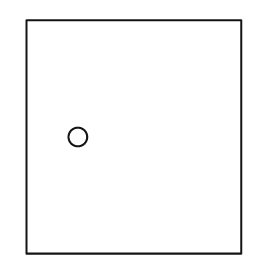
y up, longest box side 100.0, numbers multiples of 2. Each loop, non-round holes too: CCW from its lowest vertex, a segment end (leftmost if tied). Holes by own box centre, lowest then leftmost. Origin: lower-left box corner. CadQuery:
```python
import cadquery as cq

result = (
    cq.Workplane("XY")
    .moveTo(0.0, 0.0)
    .lineTo(92.0, 0.0)
    .lineTo(92.0, 100.0)
    .lineTo(0.0, 100.0)
    .close()
    .moveTo(22.0, 50.0)
    .circle(4.0)
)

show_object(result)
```